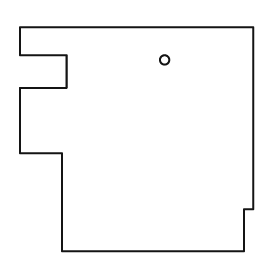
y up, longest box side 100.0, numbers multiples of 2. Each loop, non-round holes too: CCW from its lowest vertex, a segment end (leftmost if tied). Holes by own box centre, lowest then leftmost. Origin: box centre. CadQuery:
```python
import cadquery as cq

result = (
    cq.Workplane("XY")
    .moveTo(-32.0, -48.0)
    .lineTo(46.0, -48.0)
    .lineTo(46.0, -30.0)
    .lineTo(50.0, -30.0)
    .lineTo(50.0, 48.0)
    .lineTo(-50.0, 48.0)
    .lineTo(-50.0, 36.0)
    .lineTo(-30.0, 36.0)
    .lineTo(-30.0, 22.0)
    .lineTo(-50.0, 22.0)
    .lineTo(-50.0, -6.0)
    .lineTo(-32.0, -6.0)
    .close()
    .moveTo(12.0, 34.0)
    .circle(2.0)
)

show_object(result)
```